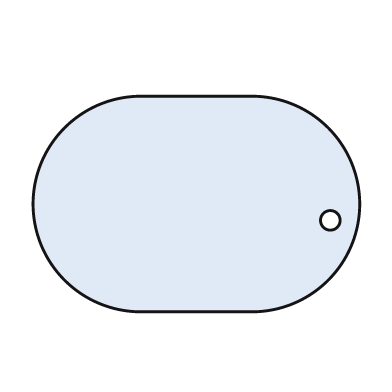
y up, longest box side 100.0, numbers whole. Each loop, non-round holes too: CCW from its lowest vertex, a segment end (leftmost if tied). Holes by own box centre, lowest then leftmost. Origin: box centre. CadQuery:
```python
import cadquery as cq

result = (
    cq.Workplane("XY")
    .moveTo(-17.0, -33.0)
    .lineTo(17.0, -33.0)
    .threePointArc((50.0, 0.0), (17.0, 33.0))
    .lineTo(-17.0, 33.0)
    .threePointArc((-50.0, 0.0), (-17.0, -33.0))
    .close()
    .moveTo(41.0, -5.0)
    .circle(3.0)
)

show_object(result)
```